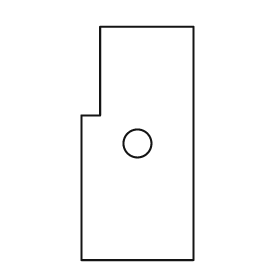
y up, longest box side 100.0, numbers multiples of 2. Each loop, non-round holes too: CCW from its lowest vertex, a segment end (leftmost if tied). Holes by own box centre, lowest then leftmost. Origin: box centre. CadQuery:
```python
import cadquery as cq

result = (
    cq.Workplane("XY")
    .moveTo(-24.0, -50.0)
    .lineTo(24.0, -50.0)
    .lineTo(24.0, 50.0)
    .lineTo(-16.0, 50.0)
    .lineTo(-16.0, 12.0)
    .lineTo(-24.0, 12.0)
    .close()
    .moveTo(0.0, 0.0)
    .circle(6.0)
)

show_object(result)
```